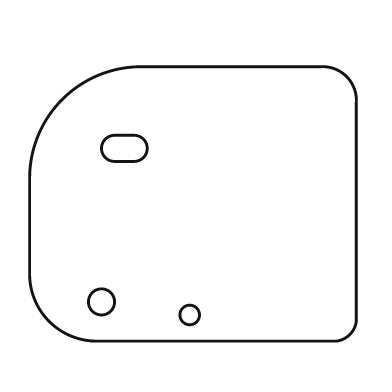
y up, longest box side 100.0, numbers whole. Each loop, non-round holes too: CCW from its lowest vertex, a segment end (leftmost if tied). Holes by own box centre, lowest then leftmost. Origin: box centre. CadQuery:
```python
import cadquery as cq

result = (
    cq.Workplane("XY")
    .moveTo(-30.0, -42.0)
    .lineTo(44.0, -42.0)
    .threePointArc((48.0, -40.0), (50.0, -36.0))
    .lineTo(50.0, 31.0)
    .threePointArc((47.0, 39.0), (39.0, 42.0))
    .lineTo(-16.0, 42.0)
    .threePointArc((-40.0, 32.0), (-50.0, 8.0))
    .lineTo(-50.0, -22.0)
    .threePointArc((-44.0, -36.0), (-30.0, -42.0))
    .close()
    .moveTo(-1.0, -34.0)
    .circle(3.0)
    .moveTo(-28.0, -30.0)
    .circle(4.0)
    .moveTo(-24.0, 13.0)
    .lineTo(-18.0, 13.0)
    .threePointArc((-14.0, 17.0), (-18.0, 21.0))
    .lineTo(-24.0, 21.0)
    .threePointArc((-28.0, 17.0), (-24.0, 13.0))
    .close()
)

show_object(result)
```